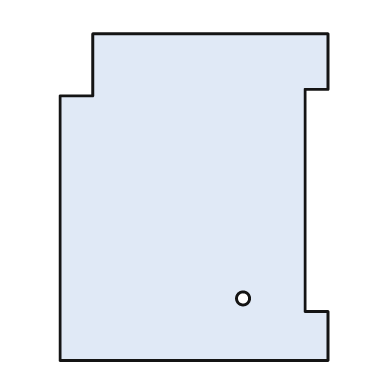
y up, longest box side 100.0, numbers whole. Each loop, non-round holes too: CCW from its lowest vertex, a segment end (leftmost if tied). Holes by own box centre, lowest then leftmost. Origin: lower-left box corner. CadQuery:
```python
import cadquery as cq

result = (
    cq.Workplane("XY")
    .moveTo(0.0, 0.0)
    .lineTo(82.0, 0.0)
    .lineTo(82.0, 15.0)
    .lineTo(75.0, 15.0)
    .lineTo(75.0, 83.0)
    .lineTo(82.0, 83.0)
    .lineTo(82.0, 100.0)
    .lineTo(10.0, 100.0)
    .lineTo(10.0, 81.0)
    .lineTo(0.0, 81.0)
    .close()
    .moveTo(56.0, 19.0)
    .circle(2.0)
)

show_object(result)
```